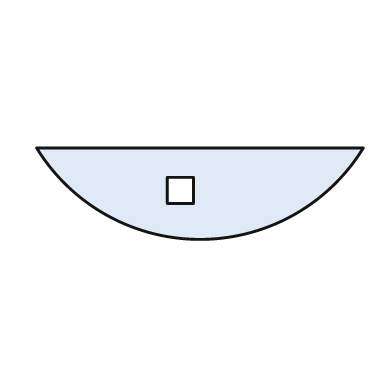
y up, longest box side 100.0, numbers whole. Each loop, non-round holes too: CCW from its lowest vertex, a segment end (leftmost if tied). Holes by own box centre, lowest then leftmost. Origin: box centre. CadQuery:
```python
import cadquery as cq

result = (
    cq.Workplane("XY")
    .moveTo(-50.0, 14.0)
    .threePointArc((0.0, -14.0), (50.0, 14.0))
    .close()
    .moveTo(-10.0, -3.0)
    .lineTo(-2.0, -3.0)
    .lineTo(-2.0, 5.0)
    .lineTo(-10.0, 5.0)
    .close()
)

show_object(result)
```